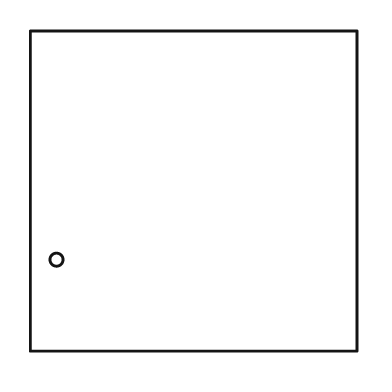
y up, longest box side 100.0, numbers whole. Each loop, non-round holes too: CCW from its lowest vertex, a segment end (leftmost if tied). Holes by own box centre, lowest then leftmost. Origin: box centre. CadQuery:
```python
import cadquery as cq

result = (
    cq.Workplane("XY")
    .moveTo(-50.0, -49.0)
    .lineTo(50.0, -49.0)
    .lineTo(50.0, 49.0)
    .lineTo(-50.0, 49.0)
    .close()
    .moveTo(-42.0, -21.0)
    .circle(2.0)
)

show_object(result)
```